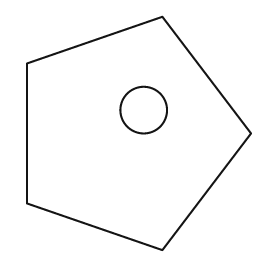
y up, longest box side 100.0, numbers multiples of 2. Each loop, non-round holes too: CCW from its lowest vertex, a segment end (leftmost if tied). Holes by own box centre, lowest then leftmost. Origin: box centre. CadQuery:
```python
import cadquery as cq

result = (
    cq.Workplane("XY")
    .moveTo(10.0, -50.0)
    .lineTo(48.0, 0.0)
    .lineTo(10.0, 50.0)
    .lineTo(-48.0, 30.0)
    .lineTo(-48.0, -30.0)
    .close()
    .moveTo(2.0, 10.0)
    .circle(10.0)
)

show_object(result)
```